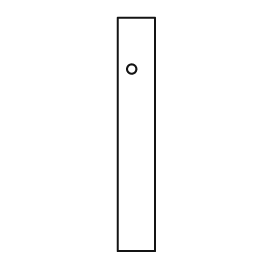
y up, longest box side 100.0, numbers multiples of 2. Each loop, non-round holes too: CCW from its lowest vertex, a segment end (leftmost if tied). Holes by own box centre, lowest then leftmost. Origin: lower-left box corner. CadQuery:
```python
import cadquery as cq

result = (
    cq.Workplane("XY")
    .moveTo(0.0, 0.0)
    .lineTo(16.0, 0.0)
    .lineTo(16.0, 100.0)
    .lineTo(0.0, 100.0)
    .close()
    .moveTo(6.0, 78.0)
    .circle(2.0)
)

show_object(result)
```